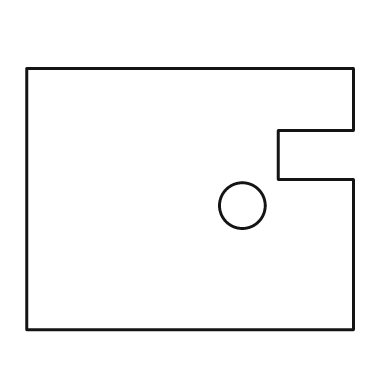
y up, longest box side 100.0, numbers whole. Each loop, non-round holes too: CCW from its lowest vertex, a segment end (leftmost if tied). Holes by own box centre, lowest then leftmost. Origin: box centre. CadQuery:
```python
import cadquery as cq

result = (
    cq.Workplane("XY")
    .moveTo(-50.0, -40.0)
    .lineTo(50.0, -40.0)
    .lineTo(50.0, 6.0)
    .lineTo(27.0, 6.0)
    .lineTo(27.0, 21.0)
    .lineTo(50.0, 21.0)
    .lineTo(50.0, 40.0)
    .lineTo(-50.0, 40.0)
    .close()
    .moveTo(16.0, -2.0)
    .circle(7.0)
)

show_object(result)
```